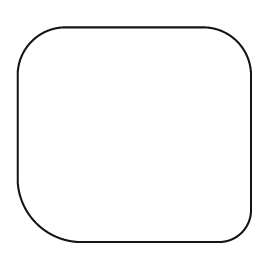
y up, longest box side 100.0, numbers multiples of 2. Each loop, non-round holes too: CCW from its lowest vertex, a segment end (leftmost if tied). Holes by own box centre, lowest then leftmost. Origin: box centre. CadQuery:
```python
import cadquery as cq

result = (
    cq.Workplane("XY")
    .moveTo(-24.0, -46.0)
    .lineTo(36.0, -46.0)
    .threePointArc((46.0, -42.0), (50.0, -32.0))
    .lineTo(50.0, 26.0)
    .threePointArc((44.0, 40.0), (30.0, 46.0))
    .lineTo(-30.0, 46.0)
    .threePointArc((-44.0, 40.0), (-50.0, 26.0))
    .lineTo(-50.0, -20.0)
    .threePointArc((-42.0, -38.0), (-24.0, -46.0))
    .close()
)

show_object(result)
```